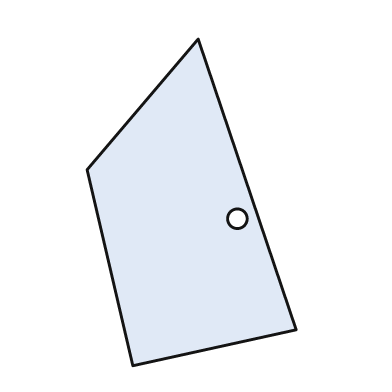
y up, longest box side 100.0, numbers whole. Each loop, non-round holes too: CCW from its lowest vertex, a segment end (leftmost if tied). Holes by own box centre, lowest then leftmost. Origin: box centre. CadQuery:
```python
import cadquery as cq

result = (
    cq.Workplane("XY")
    .moveTo(-18.0, -50.0)
    .lineTo(32.0, -39.0)
    .lineTo(2.0, 50.0)
    .lineTo(-32.0, 10.0)
    .close()
    .moveTo(14.0, -5.0)
    .circle(3.0)
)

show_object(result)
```